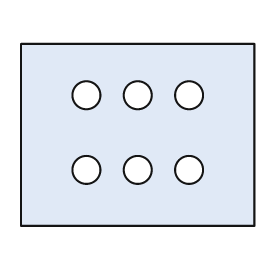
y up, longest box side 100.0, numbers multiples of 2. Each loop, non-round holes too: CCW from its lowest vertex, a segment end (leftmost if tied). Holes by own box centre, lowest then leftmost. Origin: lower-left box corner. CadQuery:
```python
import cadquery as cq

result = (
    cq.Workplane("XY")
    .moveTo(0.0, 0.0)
    .lineTo(100.0, 0.0)
    .lineTo(100.0, 78.0)
    .lineTo(0.0, 78.0)
    .close()
    .moveTo(28.0, 24.0)
    .circle(6.0)
    .moveTo(50.0, 24.0)
    .circle(6.0)
    .moveTo(72.0, 24.0)
    .circle(6.0)
    .moveTo(28.0, 56.0)
    .circle(6.0)
    .moveTo(50.0, 56.0)
    .circle(6.0)
    .moveTo(72.0, 56.0)
    .circle(6.0)
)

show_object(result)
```